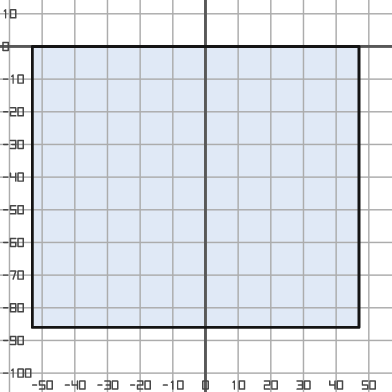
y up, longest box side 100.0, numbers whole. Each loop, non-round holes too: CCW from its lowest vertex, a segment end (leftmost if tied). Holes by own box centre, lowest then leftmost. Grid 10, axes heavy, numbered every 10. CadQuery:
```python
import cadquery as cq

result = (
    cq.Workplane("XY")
    .moveTo(-53.0, -86.0)
    .lineTo(47.0, -86.0)
    .lineTo(47.0, 0.0)
    .lineTo(-53.0, 0.0)
    .close()
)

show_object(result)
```